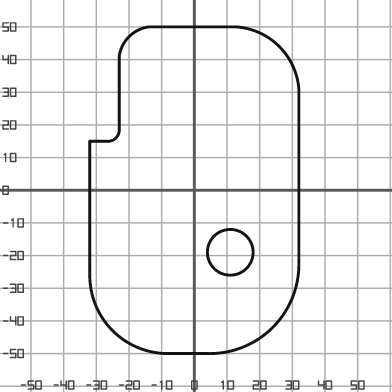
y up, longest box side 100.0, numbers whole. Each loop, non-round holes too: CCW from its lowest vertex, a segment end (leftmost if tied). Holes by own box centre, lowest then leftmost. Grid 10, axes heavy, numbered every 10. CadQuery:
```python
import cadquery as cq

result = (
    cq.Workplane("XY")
    .moveTo(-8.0, -50.0)
    .lineTo(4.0, -50.0)
    .threePointArc((24.0, -42.0), (32.0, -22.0))
    .lineTo(32.0, 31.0)
    .threePointArc((26.0, 44.0), (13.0, 50.0))
    .lineTo(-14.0, 50.0)
    .threePointArc((-20.0, 47.0), (-23.0, 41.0))
    .lineTo(-23.0, 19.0)
    .threePointArc((-24.0, 16.0), (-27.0, 15.0))
    .lineTo(-32.0, 15.0)
    .lineTo(-32.0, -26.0)
    .threePointArc((-25.0, -43.0), (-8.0, -50.0))
    .close()
    .moveTo(11.0, -19.0)
    .circle(7.0)
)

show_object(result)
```